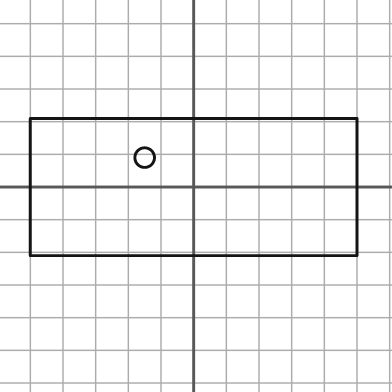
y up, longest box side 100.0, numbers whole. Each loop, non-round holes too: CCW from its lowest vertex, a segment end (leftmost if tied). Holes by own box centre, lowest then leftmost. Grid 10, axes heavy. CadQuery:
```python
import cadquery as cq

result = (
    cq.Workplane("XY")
    .moveTo(-50.0, -21.0)
    .lineTo(50.0, -21.0)
    .lineTo(50.0, 21.0)
    .lineTo(-50.0, 21.0)
    .close()
    .moveTo(-15.0, 9.0)
    .circle(3.0)
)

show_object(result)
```